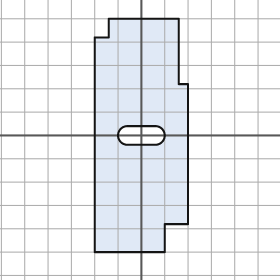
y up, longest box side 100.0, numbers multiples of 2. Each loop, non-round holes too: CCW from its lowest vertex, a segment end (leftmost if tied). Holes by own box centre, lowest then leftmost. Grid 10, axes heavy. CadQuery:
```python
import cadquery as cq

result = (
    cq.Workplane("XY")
    .moveTo(-20.0, -50.0)
    .lineTo(10.0, -50.0)
    .lineTo(10.0, -38.0)
    .lineTo(20.0, -38.0)
    .lineTo(20.0, 22.0)
    .lineTo(16.0, 22.0)
    .lineTo(16.0, 50.0)
    .lineTo(-14.0, 50.0)
    .lineTo(-14.0, 42.0)
    .lineTo(-20.0, 42.0)
    .close()
    .moveTo(-6.0, -4.0)
    .lineTo(6.0, -4.0)
    .threePointArc((10.0, 0.0), (6.0, 4.0))
    .lineTo(-6.0, 4.0)
    .threePointArc((-10.0, 0.0), (-6.0, -4.0))
    .close()
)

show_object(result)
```